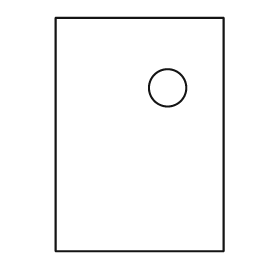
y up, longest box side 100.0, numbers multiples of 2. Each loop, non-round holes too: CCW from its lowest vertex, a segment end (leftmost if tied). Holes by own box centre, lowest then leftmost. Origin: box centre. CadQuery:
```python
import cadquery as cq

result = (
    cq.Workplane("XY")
    .moveTo(-36.0, -50.0)
    .lineTo(36.0, -50.0)
    .lineTo(36.0, 50.0)
    .lineTo(-36.0, 50.0)
    .close()
    .moveTo(12.0, 20.0)
    .circle(8.0)
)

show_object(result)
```